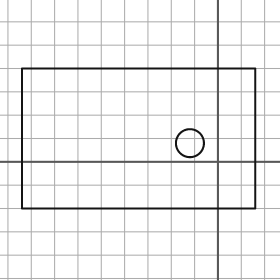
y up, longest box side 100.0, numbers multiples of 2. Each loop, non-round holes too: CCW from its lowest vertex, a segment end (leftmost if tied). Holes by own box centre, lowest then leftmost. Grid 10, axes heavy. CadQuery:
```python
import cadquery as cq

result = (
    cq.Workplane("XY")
    .moveTo(-84.0, -20.0)
    .lineTo(16.0, -20.0)
    .lineTo(16.0, 40.0)
    .lineTo(-84.0, 40.0)
    .close()
    .moveTo(-12.0, 8.0)
    .circle(6.0)
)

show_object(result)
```